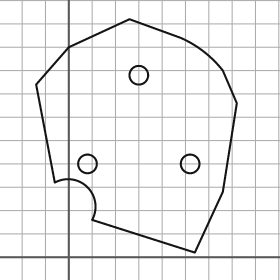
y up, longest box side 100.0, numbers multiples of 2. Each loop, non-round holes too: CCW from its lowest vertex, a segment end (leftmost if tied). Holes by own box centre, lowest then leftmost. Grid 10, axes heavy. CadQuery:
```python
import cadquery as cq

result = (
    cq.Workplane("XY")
    .moveTo(54.0, 2.0)
    .lineTo(66.0, 28.0)
    .lineTo(72.0, 66.0)
    .lineTo(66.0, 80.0)
    .threePointArc((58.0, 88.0), (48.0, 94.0))
    .lineTo(26.0, 102.0)
    .lineTo(0.0, 90.0)
    .lineTo(-14.0, 74.0)
    .lineTo(-6.0, 32.0)
    .threePointArc((8.0, 30.0), (10.0, 16.0))
    .close()
    .moveTo(8.0, 40.0)
    .circle(4.0)
    .moveTo(52.0, 40.0)
    .circle(4.0)
    .moveTo(30.0, 78.0)
    .circle(4.0)
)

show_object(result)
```